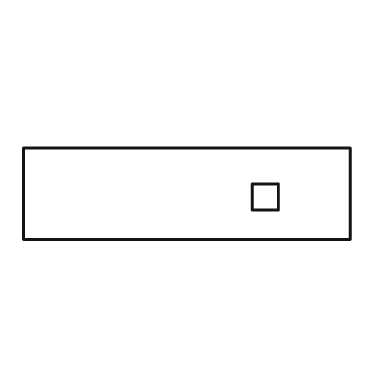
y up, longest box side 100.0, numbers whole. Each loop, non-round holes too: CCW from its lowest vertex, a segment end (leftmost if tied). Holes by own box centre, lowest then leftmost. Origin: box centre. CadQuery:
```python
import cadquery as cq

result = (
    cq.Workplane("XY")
    .moveTo(-50.0, -14.0)
    .lineTo(50.0, -14.0)
    .lineTo(50.0, 14.0)
    .lineTo(-50.0, 14.0)
    .close()
    .moveTo(20.0, -5.0)
    .lineTo(28.0, -5.0)
    .lineTo(28.0, 3.0)
    .lineTo(20.0, 3.0)
    .close()
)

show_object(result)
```